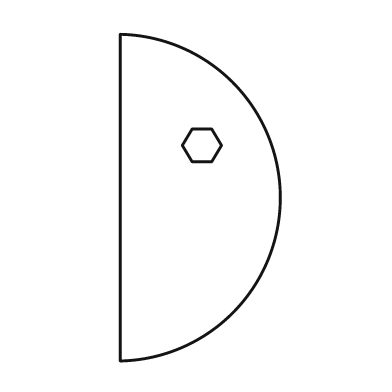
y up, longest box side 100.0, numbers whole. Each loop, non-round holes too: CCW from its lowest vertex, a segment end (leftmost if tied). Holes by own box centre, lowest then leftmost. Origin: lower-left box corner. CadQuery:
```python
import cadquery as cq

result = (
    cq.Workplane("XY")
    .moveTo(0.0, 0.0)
    .threePointArc((49.0, 50.0), (0.0, 100.0))
    .close()
    .moveTo(22.0, 61.0)
    .lineTo(28.0, 61.0)
    .lineTo(31.0, 66.0)
    .lineTo(28.0, 71.0)
    .lineTo(22.0, 71.0)
    .lineTo(19.0, 66.0)
    .close()
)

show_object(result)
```